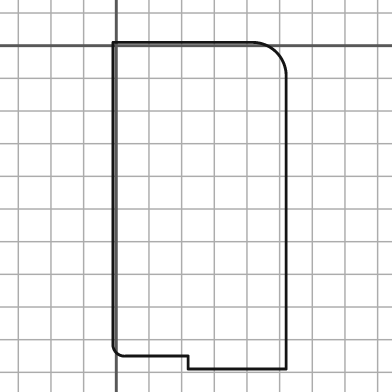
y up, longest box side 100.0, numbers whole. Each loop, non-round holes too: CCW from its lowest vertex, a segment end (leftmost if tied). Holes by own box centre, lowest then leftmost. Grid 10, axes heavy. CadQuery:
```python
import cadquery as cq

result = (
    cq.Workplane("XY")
    .moveTo(22.0, -99.0)
    .lineTo(52.0, -99.0)
    .lineTo(52.0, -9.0)
    .threePointArc((49.0, -2.0), (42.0, 1.0))
    .lineTo(-1.0, 1.0)
    .lineTo(-1.0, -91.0)
    .threePointArc((0.0, -94.0), (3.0, -95.0))
    .lineTo(22.0, -95.0)
    .close()
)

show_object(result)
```